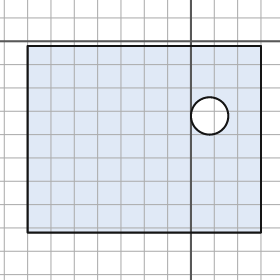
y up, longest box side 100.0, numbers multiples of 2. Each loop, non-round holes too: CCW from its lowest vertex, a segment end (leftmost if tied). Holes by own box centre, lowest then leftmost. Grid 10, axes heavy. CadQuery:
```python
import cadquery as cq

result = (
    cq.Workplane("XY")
    .moveTo(-70.0, -82.0)
    .lineTo(30.0, -82.0)
    .lineTo(30.0, -2.0)
    .lineTo(-70.0, -2.0)
    .close()
    .moveTo(8.0, -32.0)
    .circle(8.0)
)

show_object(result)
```